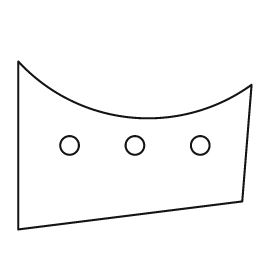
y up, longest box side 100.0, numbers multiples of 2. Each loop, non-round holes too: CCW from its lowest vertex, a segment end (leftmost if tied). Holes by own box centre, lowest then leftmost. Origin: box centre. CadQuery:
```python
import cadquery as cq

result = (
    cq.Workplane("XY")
    .moveTo(-50.0, -36.0)
    .lineTo(46.0, -24.0)
    .lineTo(50.0, 26.0)
    .threePointArc((-2.0, 12.0), (-50.0, 36.0))
    .close()
    .moveTo(-28.0, 0.0)
    .circle(4.0)
    .moveTo(0.0, 0.0)
    .circle(4.0)
    .moveTo(28.0, 0.0)
    .circle(4.0)
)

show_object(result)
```